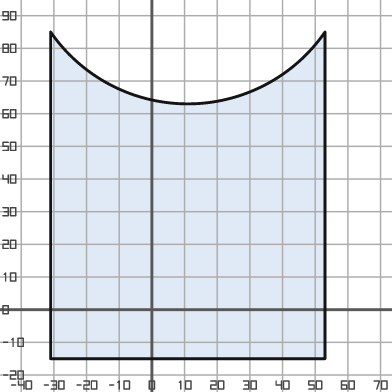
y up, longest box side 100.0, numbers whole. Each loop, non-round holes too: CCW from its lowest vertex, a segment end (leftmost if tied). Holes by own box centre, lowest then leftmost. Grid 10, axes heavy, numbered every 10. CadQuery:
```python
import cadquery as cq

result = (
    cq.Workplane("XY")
    .moveTo(-31.0, -15.0)
    .lineTo(53.0, -15.0)
    .lineTo(53.0, 85.0)
    .threePointArc((11.0, 63.0), (-31.0, 85.0))
    .close()
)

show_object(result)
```